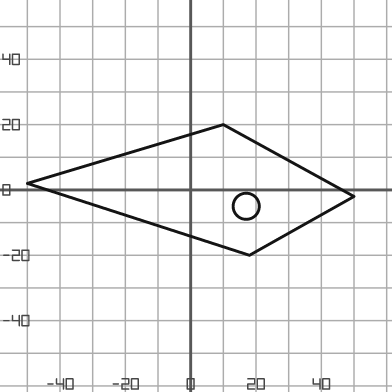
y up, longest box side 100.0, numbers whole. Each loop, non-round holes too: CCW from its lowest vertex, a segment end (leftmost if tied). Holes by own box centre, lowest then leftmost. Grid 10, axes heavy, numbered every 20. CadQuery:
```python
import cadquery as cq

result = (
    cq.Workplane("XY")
    .moveTo(18.0, -20.0)
    .lineTo(50.0, -2.0)
    .lineTo(10.0, 20.0)
    .lineTo(-50.0, 2.0)
    .close()
    .moveTo(17.0, -5.0)
    .circle(4.0)
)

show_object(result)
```